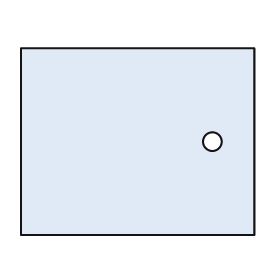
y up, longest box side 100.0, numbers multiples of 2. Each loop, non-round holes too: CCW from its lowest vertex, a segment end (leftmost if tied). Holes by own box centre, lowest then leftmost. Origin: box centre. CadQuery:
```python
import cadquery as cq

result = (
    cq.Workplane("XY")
    .moveTo(-50.0, -40.0)
    .lineTo(50.0, -40.0)
    .lineTo(50.0, 40.0)
    .lineTo(-50.0, 40.0)
    .close()
    .moveTo(32.0, 0.0)
    .circle(4.0)
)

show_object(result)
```